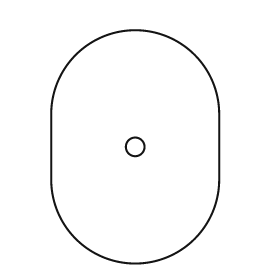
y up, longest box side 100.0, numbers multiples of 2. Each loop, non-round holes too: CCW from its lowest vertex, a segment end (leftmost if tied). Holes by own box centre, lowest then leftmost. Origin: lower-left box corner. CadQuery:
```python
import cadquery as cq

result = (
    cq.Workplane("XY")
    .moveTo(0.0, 36.0)
    .threePointArc((36.0, 0.0), (72.0, 36.0))
    .lineTo(72.0, 64.0)
    .threePointArc((36.0, 100.0), (0.0, 64.0))
    .close()
    .moveTo(36.0, 50.0)
    .circle(4.0)
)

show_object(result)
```